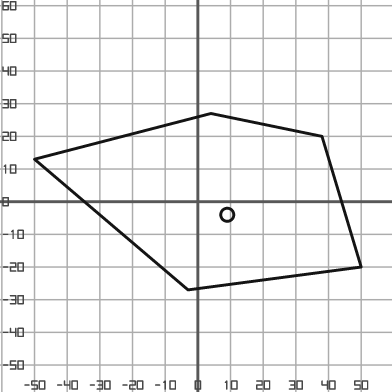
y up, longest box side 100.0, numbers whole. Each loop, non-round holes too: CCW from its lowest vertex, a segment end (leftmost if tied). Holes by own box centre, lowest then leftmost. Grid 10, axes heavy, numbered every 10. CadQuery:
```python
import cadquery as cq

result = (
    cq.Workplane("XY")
    .moveTo(-3.0, -27.0)
    .lineTo(50.0, -20.0)
    .lineTo(38.0, 20.0)
    .lineTo(4.0, 27.0)
    .lineTo(-50.0, 13.0)
    .close()
    .moveTo(9.0, -4.0)
    .circle(2.0)
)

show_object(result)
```